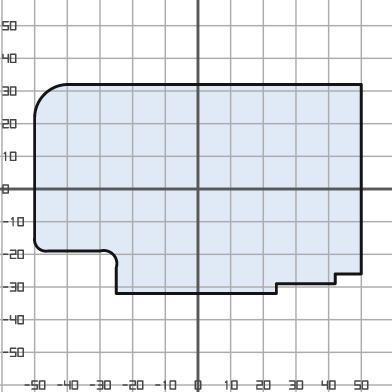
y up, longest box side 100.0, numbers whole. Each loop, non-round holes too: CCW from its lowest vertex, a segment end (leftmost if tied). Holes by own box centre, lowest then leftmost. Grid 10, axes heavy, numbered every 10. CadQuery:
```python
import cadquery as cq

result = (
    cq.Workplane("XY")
    .moveTo(-25.0, -32.0)
    .lineTo(24.0, -32.0)
    .lineTo(24.0, -29.0)
    .lineTo(42.0, -29.0)
    .lineTo(42.0, -26.0)
    .lineTo(50.0, -26.0)
    .lineTo(50.0, 32.0)
    .lineTo(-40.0, 32.0)
    .threePointArc((-47.0, 29.0), (-50.0, 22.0))
    .lineTo(-50.0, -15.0)
    .threePointArc((-49.0, -18.0), (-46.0, -19.0))
    .lineTo(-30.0, -19.0)
    .threePointArc((-26.0, -20.0), (-25.0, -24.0))
    .close()
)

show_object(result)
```